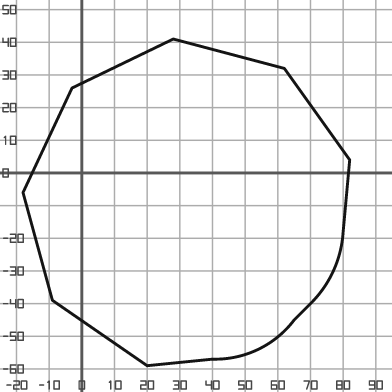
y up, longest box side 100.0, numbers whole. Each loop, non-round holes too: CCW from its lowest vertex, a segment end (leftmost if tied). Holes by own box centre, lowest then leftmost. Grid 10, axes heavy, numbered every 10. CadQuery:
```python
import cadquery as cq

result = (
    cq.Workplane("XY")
    .moveTo(20.0, -59.0)
    .lineTo(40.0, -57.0)
    .threePointArc((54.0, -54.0), (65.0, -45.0))
    .lineTo(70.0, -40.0)
    .threePointArc((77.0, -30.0), (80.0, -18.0))
    .lineTo(82.0, 4.0)
    .lineTo(62.0, 32.0)
    .lineTo(28.0, 41.0)
    .lineTo(-3.0, 26.0)
    .lineTo(-18.0, -6.0)
    .lineTo(-9.0, -39.0)
    .close()
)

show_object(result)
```